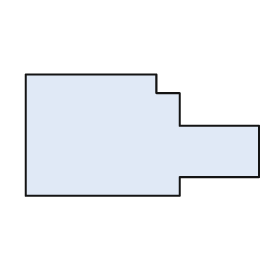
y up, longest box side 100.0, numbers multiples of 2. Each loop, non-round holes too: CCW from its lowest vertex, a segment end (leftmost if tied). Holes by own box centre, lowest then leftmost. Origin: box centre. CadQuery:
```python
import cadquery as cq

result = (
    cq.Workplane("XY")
    .moveTo(-50.0, -26.0)
    .lineTo(16.0, -26.0)
    .lineTo(16.0, -18.0)
    .lineTo(50.0, -18.0)
    .lineTo(50.0, 4.0)
    .lineTo(16.0, 4.0)
    .lineTo(16.0, 18.0)
    .lineTo(6.0, 18.0)
    .lineTo(6.0, 26.0)
    .lineTo(-50.0, 26.0)
    .close()
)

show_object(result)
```